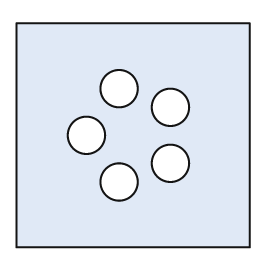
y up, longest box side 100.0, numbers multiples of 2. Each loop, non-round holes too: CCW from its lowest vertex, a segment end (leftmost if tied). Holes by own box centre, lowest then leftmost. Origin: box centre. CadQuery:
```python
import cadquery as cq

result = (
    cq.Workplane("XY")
    .moveTo(-50.0, -48.0)
    .lineTo(50.0, -48.0)
    .lineTo(50.0, 48.0)
    .lineTo(-50.0, 48.0)
    .close()
    .moveTo(-6.0, -20.0)
    .circle(8.0)
    .moveTo(16.0, -12.0)
    .circle(8.0)
    .moveTo(-20.0, 0.0)
    .circle(8.0)
    .moveTo(16.0, 12.0)
    .circle(8.0)
    .moveTo(-6.0, 20.0)
    .circle(8.0)
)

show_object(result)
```